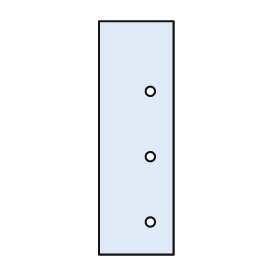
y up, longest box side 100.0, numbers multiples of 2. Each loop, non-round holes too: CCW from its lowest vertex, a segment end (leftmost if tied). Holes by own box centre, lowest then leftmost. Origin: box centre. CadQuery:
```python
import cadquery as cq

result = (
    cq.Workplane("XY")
    .moveTo(-16.0, -50.0)
    .lineTo(16.0, -50.0)
    .lineTo(16.0, 50.0)
    .lineTo(-16.0, 50.0)
    .close()
    .moveTo(6.0, -36.0)
    .circle(2.0)
    .moveTo(6.0, -8.0)
    .circle(2.0)
    .moveTo(6.0, 20.0)
    .circle(2.0)
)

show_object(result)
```